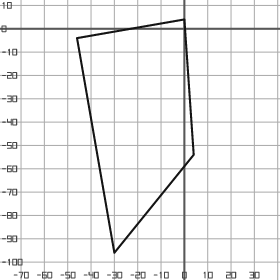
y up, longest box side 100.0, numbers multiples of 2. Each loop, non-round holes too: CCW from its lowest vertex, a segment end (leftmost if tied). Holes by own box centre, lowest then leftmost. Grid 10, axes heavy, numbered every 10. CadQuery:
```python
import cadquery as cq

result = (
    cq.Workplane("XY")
    .moveTo(-30.0, -96.0)
    .lineTo(4.0, -54.0)
    .lineTo(0.0, 4.0)
    .lineTo(-46.0, -4.0)
    .close()
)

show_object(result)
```